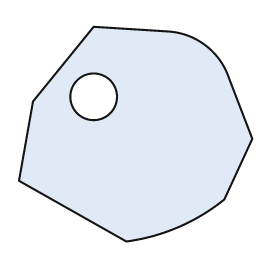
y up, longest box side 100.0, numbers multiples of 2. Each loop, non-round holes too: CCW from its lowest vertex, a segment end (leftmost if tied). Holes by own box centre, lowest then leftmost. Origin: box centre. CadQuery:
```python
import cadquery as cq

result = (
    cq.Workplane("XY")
    .moveTo(-4.0, -46.0)
    .threePointArc((18.0, -40.0), (38.0, -28.0))
    .lineTo(50.0, -2.0)
    .lineTo(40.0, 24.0)
    .threePointArc((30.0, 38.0), (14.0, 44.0))
    .lineTo(-18.0, 46.0)
    .lineTo(-44.0, 14.0)
    .lineTo(-50.0, -20.0)
    .close()
    .moveTo(-18.0, 16.0)
    .circle(10.0)
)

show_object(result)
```